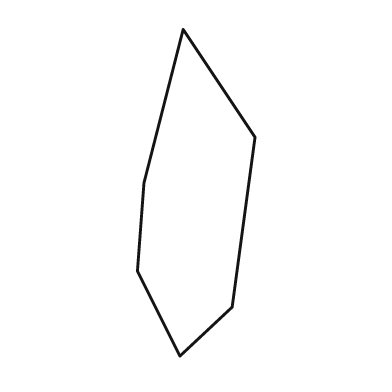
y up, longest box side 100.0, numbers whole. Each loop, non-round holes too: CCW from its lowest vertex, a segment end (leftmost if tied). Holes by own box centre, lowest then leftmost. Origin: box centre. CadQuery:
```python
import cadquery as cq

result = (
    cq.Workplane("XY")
    .moveTo(-5.0, -50.0)
    .lineTo(11.0, -35.0)
    .lineTo(18.0, 17.0)
    .lineTo(-4.0, 50.0)
    .lineTo(-16.0, 3.0)
    .lineTo(-18.0, -24.0)
    .close()
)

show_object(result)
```